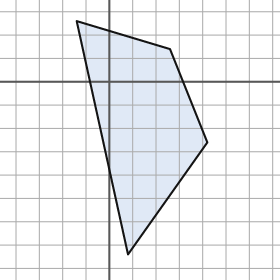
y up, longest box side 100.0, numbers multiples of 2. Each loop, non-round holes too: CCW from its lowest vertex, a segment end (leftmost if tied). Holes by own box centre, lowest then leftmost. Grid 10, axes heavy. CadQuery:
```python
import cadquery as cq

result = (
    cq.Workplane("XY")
    .moveTo(8.0, -74.0)
    .lineTo(42.0, -26.0)
    .lineTo(26.0, 14.0)
    .lineTo(-14.0, 26.0)
    .close()
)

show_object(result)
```